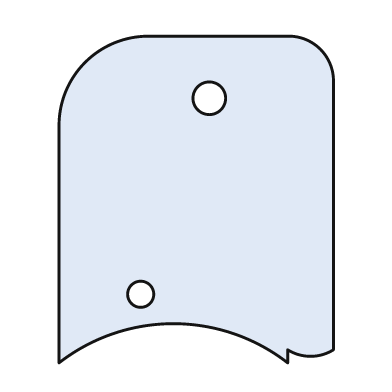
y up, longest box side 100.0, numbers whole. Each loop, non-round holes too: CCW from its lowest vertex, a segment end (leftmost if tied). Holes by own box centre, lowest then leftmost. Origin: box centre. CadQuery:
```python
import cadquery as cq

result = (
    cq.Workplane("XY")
    .moveTo(-42.0, -50.0)
    .threePointArc((-7.0, -38.0), (28.0, -50.0))
    .lineTo(28.0, -46.0)
    .threePointArc((35.0, -48.0), (42.0, -46.0))
    .lineTo(42.0, 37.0)
    .threePointArc((38.0, 46.0), (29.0, 50.0))
    .lineTo(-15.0, 50.0)
    .threePointArc((-34.0, 42.0), (-42.0, 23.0))
    .close()
    .moveTo(-17.0, -29.0)
    .circle(4.0)
    .moveTo(4.0, 31.0)
    .circle(5.0)
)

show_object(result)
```